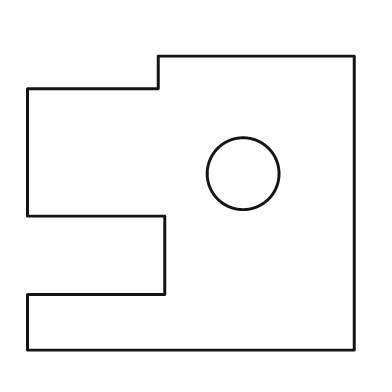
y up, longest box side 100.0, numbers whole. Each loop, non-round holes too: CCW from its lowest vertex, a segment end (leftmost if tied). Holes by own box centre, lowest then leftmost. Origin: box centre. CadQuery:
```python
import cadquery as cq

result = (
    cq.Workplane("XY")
    .moveTo(-50.0, -45.0)
    .lineTo(50.0, -45.0)
    .lineTo(50.0, 45.0)
    .lineTo(-10.0, 45.0)
    .lineTo(-10.0, 35.0)
    .lineTo(-50.0, 35.0)
    .lineTo(-50.0, -4.0)
    .lineTo(-8.0, -4.0)
    .lineTo(-8.0, -28.0)
    .lineTo(-50.0, -28.0)
    .close()
    .moveTo(16.0, 9.0)
    .circle(11.0)
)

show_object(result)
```